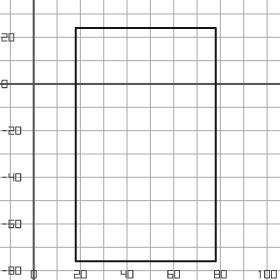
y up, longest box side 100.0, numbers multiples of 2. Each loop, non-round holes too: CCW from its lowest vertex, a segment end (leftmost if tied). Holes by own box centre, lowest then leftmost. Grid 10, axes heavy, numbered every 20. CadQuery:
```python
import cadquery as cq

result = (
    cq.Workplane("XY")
    .moveTo(18.0, -76.0)
    .lineTo(78.0, -76.0)
    .lineTo(78.0, 24.0)
    .lineTo(18.0, 24.0)
    .close()
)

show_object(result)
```